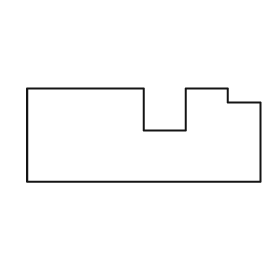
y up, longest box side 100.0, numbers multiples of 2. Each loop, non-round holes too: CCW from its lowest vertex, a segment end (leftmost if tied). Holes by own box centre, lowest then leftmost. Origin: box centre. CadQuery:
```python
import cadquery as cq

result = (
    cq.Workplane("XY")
    .moveTo(-50.0, -20.0)
    .lineTo(50.0, -20.0)
    .lineTo(50.0, 14.0)
    .lineTo(36.0, 14.0)
    .lineTo(36.0, 20.0)
    .lineTo(18.0, 20.0)
    .lineTo(18.0, 2.0)
    .lineTo(0.0, 2.0)
    .lineTo(0.0, 20.0)
    .lineTo(-50.0, 20.0)
    .close()
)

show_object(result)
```